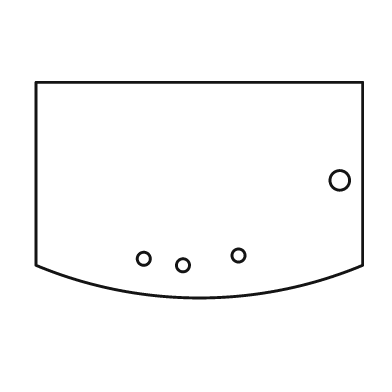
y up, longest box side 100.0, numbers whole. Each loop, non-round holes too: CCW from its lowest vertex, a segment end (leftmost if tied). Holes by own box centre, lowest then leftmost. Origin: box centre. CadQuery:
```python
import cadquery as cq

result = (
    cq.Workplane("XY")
    .moveTo(-50.0, -23.0)
    .threePointArc((0.0, -33.0), (50.0, -23.0))
    .lineTo(50.0, 33.0)
    .lineTo(-50.0, 33.0)
    .close()
    .moveTo(-5.0, -23.0)
    .circle(2.0)
    .moveTo(-17.0, -21.0)
    .circle(2.0)
    .moveTo(12.0, -20.0)
    .circle(2.0)
    .moveTo(43.0, 3.0)
    .circle(3.0)
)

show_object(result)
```